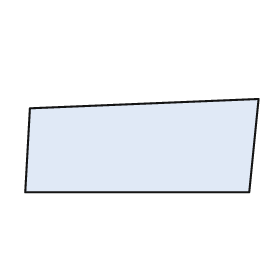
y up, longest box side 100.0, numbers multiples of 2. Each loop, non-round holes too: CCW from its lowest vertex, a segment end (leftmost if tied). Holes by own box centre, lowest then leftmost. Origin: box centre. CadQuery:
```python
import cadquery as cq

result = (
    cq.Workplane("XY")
    .moveTo(-50.0, -20.0)
    .lineTo(46.0, -20.0)
    .lineTo(50.0, 20.0)
    .lineTo(-48.0, 16.0)
    .close()
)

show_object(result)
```